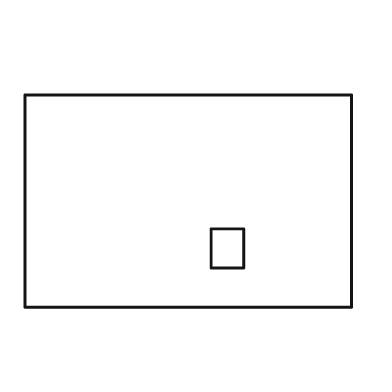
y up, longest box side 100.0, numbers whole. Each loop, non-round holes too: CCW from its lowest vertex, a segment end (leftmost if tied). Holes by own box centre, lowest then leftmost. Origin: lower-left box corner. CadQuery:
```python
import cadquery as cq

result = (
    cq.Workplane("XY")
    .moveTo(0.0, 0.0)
    .lineTo(100.0, 0.0)
    .lineTo(100.0, 65.0)
    .lineTo(0.0, 65.0)
    .close()
    .moveTo(57.0, 12.0)
    .lineTo(67.0, 12.0)
    .lineTo(67.0, 24.0)
    .lineTo(57.0, 24.0)
    .close()
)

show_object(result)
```